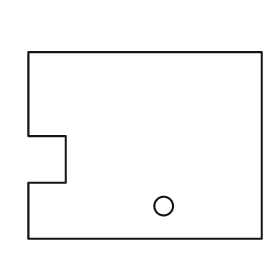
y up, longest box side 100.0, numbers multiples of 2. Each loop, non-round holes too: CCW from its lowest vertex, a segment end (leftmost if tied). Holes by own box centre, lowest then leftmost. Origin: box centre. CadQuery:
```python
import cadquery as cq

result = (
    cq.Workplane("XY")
    .moveTo(-50.0, -40.0)
    .lineTo(50.0, -40.0)
    .lineTo(50.0, 40.0)
    .lineTo(-50.0, 40.0)
    .lineTo(-50.0, 4.0)
    .lineTo(-34.0, 4.0)
    .lineTo(-34.0, -16.0)
    .lineTo(-50.0, -16.0)
    .close()
    .moveTo(8.0, -26.0)
    .circle(4.0)
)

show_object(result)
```